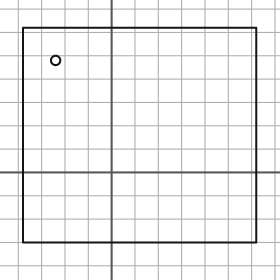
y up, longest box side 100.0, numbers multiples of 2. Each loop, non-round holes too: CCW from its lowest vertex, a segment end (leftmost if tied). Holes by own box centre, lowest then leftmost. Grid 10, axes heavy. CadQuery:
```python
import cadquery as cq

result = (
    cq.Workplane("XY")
    .moveTo(-38.0, -30.0)
    .lineTo(62.0, -30.0)
    .lineTo(62.0, 62.0)
    .lineTo(-38.0, 62.0)
    .close()
    .moveTo(-24.0, 48.0)
    .circle(2.0)
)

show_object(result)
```